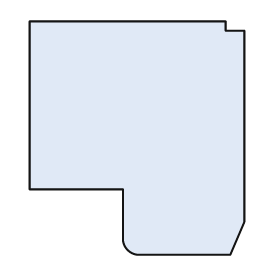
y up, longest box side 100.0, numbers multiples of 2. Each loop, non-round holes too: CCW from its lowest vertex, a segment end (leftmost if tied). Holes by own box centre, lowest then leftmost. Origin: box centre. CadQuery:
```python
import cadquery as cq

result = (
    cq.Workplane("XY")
    .moveTo(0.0, -50.0)
    .lineTo(40.0, -50.0)
    .lineTo(46.0, -36.0)
    .lineTo(46.0, 46.0)
    .lineTo(38.0, 46.0)
    .lineTo(38.0, 50.0)
    .lineTo(-46.0, 50.0)
    .lineTo(-46.0, -22.0)
    .lineTo(-6.0, -22.0)
    .lineTo(-6.0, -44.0)
    .threePointArc((-4.0, -48.0), (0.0, -50.0))
    .close()
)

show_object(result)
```